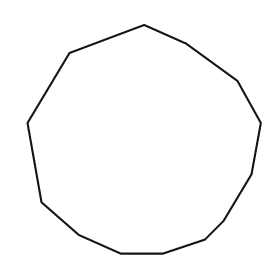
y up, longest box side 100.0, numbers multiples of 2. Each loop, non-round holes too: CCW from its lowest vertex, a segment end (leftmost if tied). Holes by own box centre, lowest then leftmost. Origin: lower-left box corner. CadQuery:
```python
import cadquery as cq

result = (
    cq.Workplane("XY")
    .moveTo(40.0, 0.0)
    .lineTo(58.0, 0.0)
    .lineTo(76.0, 6.0)
    .lineTo(84.0, 14.0)
    .lineTo(96.0, 34.0)
    .lineTo(100.0, 56.0)
    .lineTo(90.0, 74.0)
    .lineTo(68.0, 90.0)
    .lineTo(50.0, 98.0)
    .lineTo(18.0, 86.0)
    .lineTo(0.0, 56.0)
    .lineTo(6.0, 22.0)
    .lineTo(22.0, 8.0)
    .close()
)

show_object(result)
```